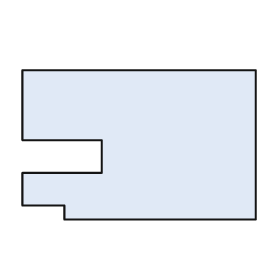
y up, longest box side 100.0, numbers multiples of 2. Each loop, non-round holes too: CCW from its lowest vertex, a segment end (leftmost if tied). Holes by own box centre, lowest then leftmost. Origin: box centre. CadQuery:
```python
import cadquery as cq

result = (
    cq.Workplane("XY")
    .moveTo(-32.0, -32.0)
    .lineTo(50.0, -32.0)
    .lineTo(50.0, 32.0)
    .lineTo(-50.0, 32.0)
    .lineTo(-50.0, 2.0)
    .lineTo(-16.0, 2.0)
    .lineTo(-16.0, -12.0)
    .lineTo(-50.0, -12.0)
    .lineTo(-50.0, -26.0)
    .lineTo(-32.0, -26.0)
    .close()
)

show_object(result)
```